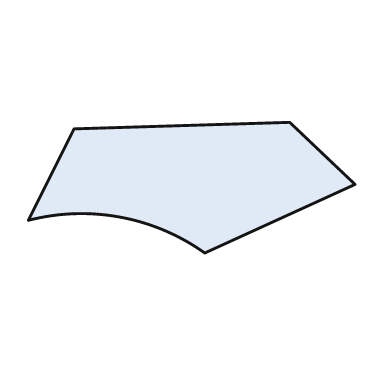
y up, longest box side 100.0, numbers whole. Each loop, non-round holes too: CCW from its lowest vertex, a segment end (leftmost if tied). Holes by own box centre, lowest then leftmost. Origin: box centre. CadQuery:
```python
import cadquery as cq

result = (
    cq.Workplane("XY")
    .moveTo(4.0, -20.0)
    .lineTo(50.0, 1.0)
    .lineTo(30.0, 20.0)
    .lineTo(-36.0, 18.0)
    .lineTo(-50.0, -10.0)
    .threePointArc((-22.0, -9.0), (4.0, -20.0))
    .close()
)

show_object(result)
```